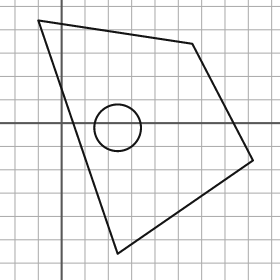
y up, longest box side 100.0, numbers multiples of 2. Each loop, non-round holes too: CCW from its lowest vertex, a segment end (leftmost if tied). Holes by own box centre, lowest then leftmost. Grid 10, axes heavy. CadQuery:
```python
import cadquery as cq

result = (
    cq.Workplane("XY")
    .moveTo(24.0, -56.0)
    .lineTo(82.0, -16.0)
    .lineTo(56.0, 34.0)
    .lineTo(-10.0, 44.0)
    .close()
    .moveTo(24.0, -2.0)
    .circle(10.0)
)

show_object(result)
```